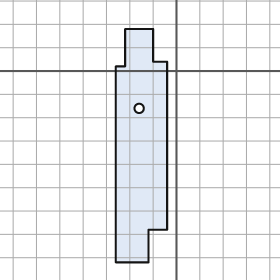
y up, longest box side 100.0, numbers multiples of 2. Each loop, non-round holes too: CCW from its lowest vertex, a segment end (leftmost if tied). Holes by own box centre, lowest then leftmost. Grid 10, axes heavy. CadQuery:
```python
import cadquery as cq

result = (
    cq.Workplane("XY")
    .moveTo(-26.0, -82.0)
    .lineTo(-12.0, -82.0)
    .lineTo(-12.0, -68.0)
    .lineTo(-4.0, -68.0)
    .lineTo(-4.0, 4.0)
    .lineTo(-10.0, 4.0)
    .lineTo(-10.0, 18.0)
    .lineTo(-22.0, 18.0)
    .lineTo(-22.0, 2.0)
    .lineTo(-26.0, 2.0)
    .close()
    .moveTo(-16.0, -16.0)
    .circle(2.0)
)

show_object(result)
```